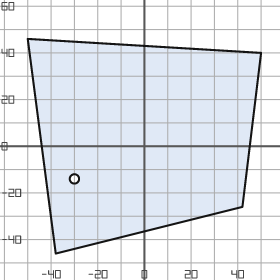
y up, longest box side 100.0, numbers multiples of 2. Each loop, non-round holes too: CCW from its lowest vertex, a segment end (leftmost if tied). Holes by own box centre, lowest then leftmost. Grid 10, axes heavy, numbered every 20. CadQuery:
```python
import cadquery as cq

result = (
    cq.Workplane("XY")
    .moveTo(-38.0, -46.0)
    .lineTo(42.0, -26.0)
    .lineTo(50.0, 40.0)
    .lineTo(-50.0, 46.0)
    .close()
    .moveTo(-30.0, -14.0)
    .circle(2.0)
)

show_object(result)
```